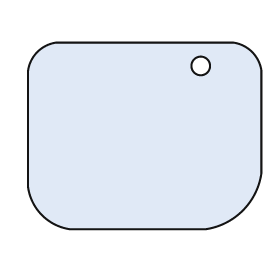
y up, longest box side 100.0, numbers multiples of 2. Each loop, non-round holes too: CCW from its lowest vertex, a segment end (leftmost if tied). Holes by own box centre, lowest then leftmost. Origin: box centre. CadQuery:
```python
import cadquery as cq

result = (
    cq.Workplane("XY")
    .moveTo(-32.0, -40.0)
    .lineTo(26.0, -40.0)
    .threePointArc((42.0, -32.0), (50.0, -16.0))
    .lineTo(50.0, 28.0)
    .threePointArc((46.0, 36.0), (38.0, 40.0))
    .lineTo(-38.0, 40.0)
    .threePointArc((-46.0, 36.0), (-50.0, 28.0))
    .lineTo(-50.0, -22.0)
    .threePointArc((-44.0, -34.0), (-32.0, -40.0))
    .close()
    .moveTo(24.0, 30.0)
    .circle(4.0)
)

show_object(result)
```